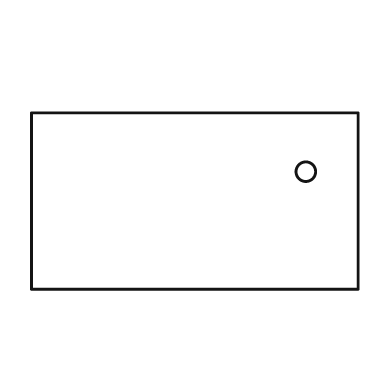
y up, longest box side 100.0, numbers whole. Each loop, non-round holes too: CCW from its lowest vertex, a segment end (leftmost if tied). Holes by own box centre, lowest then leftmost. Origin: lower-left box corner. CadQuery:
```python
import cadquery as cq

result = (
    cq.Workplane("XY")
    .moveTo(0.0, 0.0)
    .lineTo(100.0, 0.0)
    .lineTo(100.0, 54.0)
    .lineTo(0.0, 54.0)
    .close()
    .moveTo(84.0, 36.0)
    .circle(3.0)
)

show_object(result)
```